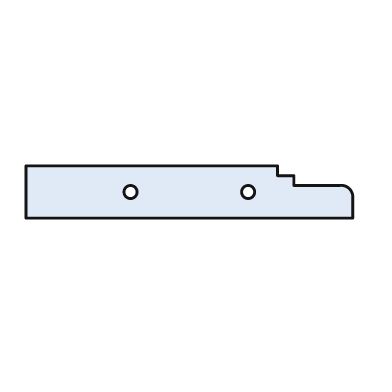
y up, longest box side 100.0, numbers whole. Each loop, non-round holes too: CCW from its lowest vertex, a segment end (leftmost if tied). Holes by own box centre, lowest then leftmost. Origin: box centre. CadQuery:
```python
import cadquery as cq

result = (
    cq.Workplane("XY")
    .moveTo(-50.0, -8.0)
    .lineTo(50.0, -8.0)
    .lineTo(50.0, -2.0)
    .threePointArc((49.0, 1.0), (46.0, 2.0))
    .lineTo(32.0, 2.0)
    .lineTo(32.0, 5.0)
    .lineTo(27.0, 5.0)
    .lineTo(27.0, 8.0)
    .lineTo(-50.0, 8.0)
    .close()
    .moveTo(-18.0, 0.0)
    .circle(2.0)
    .moveTo(18.0, 0.0)
    .circle(2.0)
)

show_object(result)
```